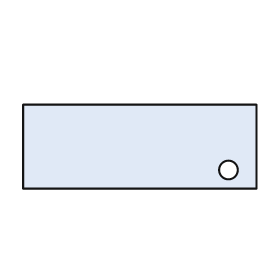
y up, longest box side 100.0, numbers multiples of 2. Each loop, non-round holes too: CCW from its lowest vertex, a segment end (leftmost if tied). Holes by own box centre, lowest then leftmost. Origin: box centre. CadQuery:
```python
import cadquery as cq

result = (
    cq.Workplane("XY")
    .moveTo(-50.0, -18.0)
    .lineTo(50.0, -18.0)
    .lineTo(50.0, 18.0)
    .lineTo(-50.0, 18.0)
    .close()
    .moveTo(38.0, -10.0)
    .circle(4.0)
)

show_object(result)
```